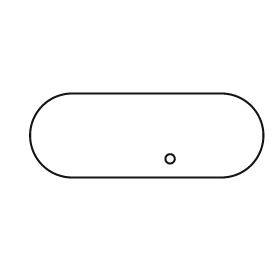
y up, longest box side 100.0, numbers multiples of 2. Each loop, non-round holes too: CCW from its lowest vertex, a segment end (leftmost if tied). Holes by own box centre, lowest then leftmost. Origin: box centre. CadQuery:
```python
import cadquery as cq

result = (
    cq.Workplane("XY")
    .moveTo(-32.0, -18.0)
    .lineTo(32.0, -18.0)
    .threePointArc((50.0, 0.0), (32.0, 18.0))
    .lineTo(-32.0, 18.0)
    .threePointArc((-50.0, 0.0), (-32.0, -18.0))
    .close()
    .moveTo(10.0, -10.0)
    .circle(2.0)
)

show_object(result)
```